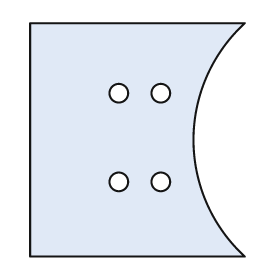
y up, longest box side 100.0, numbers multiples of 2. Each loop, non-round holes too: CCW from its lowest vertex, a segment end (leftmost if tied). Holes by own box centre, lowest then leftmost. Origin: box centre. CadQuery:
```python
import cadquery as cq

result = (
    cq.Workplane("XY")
    .moveTo(-46.0, -50.0)
    .lineTo(46.0, -50.0)
    .threePointArc((24.0, 0.0), (46.0, 50.0))
    .lineTo(-46.0, 50.0)
    .close()
    .moveTo(-8.0, -18.0)
    .circle(4.0)
    .moveTo(10.0, -18.0)
    .circle(4.0)
    .moveTo(-8.0, 20.0)
    .circle(4.0)
    .moveTo(10.0, 20.0)
    .circle(4.0)
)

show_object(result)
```